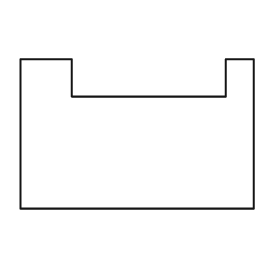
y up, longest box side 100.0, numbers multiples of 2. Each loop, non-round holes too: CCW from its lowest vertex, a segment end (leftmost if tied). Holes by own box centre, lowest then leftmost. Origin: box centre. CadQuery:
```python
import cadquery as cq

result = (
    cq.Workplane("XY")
    .moveTo(-50.0, -32.0)
    .lineTo(50.0, -32.0)
    .lineTo(50.0, 32.0)
    .lineTo(38.0, 32.0)
    .lineTo(38.0, 16.0)
    .lineTo(-28.0, 16.0)
    .lineTo(-28.0, 32.0)
    .lineTo(-50.0, 32.0)
    .close()
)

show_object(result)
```